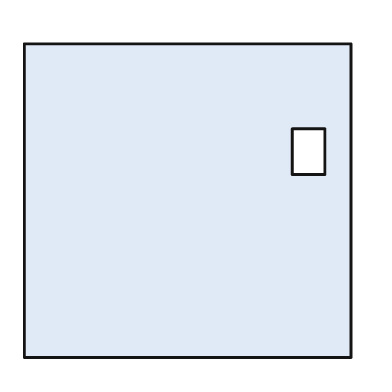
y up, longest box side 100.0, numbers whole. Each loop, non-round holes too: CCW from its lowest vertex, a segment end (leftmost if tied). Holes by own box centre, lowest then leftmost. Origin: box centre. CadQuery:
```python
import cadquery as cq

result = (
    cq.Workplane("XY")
    .moveTo(-50.0, -48.0)
    .lineTo(50.0, -48.0)
    .lineTo(50.0, 48.0)
    .lineTo(-50.0, 48.0)
    .close()
    .moveTo(32.0, 8.0)
    .lineTo(42.0, 8.0)
    .lineTo(42.0, 22.0)
    .lineTo(32.0, 22.0)
    .close()
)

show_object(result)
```